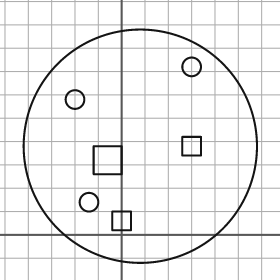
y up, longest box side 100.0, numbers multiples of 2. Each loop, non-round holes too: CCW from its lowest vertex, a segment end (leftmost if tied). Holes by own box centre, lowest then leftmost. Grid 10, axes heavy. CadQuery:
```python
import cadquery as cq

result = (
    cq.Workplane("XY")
    .moveTo(8.0, 38.0)
    .circle(50.0)
    .moveTo(-4.0, 2.0)
    .lineTo(4.0, 2.0)
    .lineTo(4.0, 10.0)
    .lineTo(-4.0, 10.0)
    .close()
    .moveTo(-14.0, 14.0)
    .circle(4.0)
    .moveTo(-12.0, 26.0)
    .lineTo(0.0, 26.0)
    .lineTo(0.0, 38.0)
    .lineTo(-12.0, 38.0)
    .close()
    .moveTo(26.0, 34.0)
    .lineTo(34.0, 34.0)
    .lineTo(34.0, 42.0)
    .lineTo(26.0, 42.0)
    .close()
    .moveTo(-20.0, 58.0)
    .circle(4.0)
    .moveTo(30.0, 72.0)
    .circle(4.0)
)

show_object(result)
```